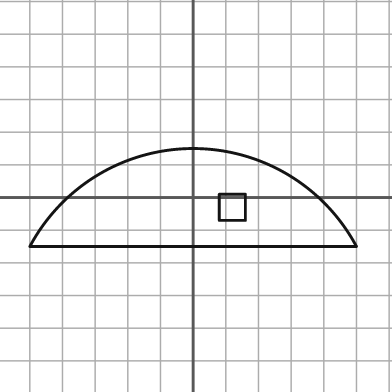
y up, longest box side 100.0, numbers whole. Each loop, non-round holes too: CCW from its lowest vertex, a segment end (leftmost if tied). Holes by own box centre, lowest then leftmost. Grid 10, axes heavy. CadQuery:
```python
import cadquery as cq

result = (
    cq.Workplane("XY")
    .moveTo(-50.0, -15.0)
    .lineTo(50.0, -15.0)
    .threePointArc((0.0, 15.0), (-50.0, -15.0))
    .close()
    .moveTo(8.0, -7.0)
    .lineTo(16.0, -7.0)
    .lineTo(16.0, 1.0)
    .lineTo(8.0, 1.0)
    .close()
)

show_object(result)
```